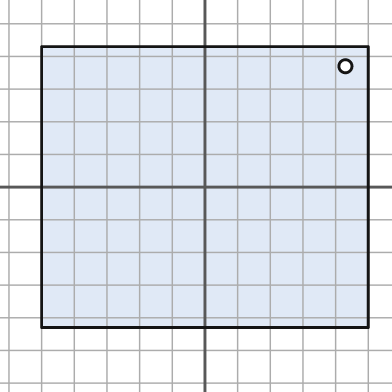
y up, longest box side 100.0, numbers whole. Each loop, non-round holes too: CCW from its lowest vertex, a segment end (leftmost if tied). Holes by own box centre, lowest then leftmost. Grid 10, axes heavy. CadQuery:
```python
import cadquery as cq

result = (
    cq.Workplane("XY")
    .moveTo(-50.0, -43.0)
    .lineTo(50.0, -43.0)
    .lineTo(50.0, 43.0)
    .lineTo(-50.0, 43.0)
    .close()
    .moveTo(43.0, 37.0)
    .circle(2.0)
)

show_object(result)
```